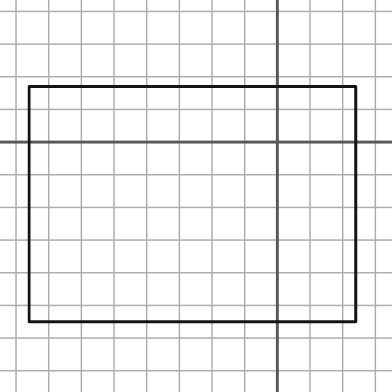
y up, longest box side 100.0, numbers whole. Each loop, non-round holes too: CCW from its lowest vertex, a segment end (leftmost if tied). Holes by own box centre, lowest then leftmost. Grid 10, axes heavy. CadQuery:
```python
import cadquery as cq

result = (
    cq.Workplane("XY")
    .moveTo(-76.0, -55.0)
    .lineTo(24.0, -55.0)
    .lineTo(24.0, 17.0)
    .lineTo(-76.0, 17.0)
    .close()
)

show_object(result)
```